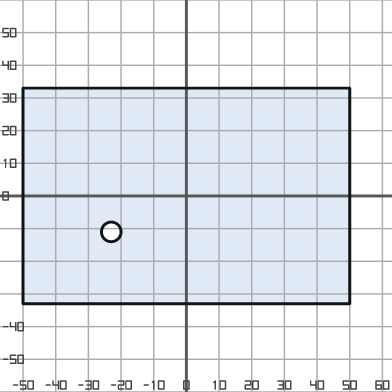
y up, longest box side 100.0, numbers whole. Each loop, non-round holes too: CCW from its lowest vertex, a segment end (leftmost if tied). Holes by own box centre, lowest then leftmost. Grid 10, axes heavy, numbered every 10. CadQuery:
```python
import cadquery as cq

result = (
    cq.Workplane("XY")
    .moveTo(-50.0, -33.0)
    .lineTo(50.0, -33.0)
    .lineTo(50.0, 33.0)
    .lineTo(-50.0, 33.0)
    .close()
    .moveTo(-23.0, -11.0)
    .circle(3.0)
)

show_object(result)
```